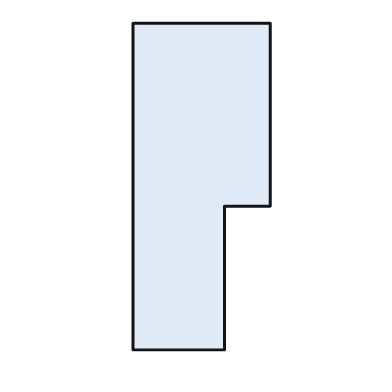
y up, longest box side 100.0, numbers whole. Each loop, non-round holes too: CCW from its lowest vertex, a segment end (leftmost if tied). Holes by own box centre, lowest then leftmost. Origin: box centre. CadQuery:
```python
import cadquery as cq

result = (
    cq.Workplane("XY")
    .moveTo(-21.0, -50.0)
    .lineTo(7.0, -50.0)
    .lineTo(7.0, -6.0)
    .lineTo(21.0, -6.0)
    .lineTo(21.0, 50.0)
    .lineTo(-21.0, 50.0)
    .close()
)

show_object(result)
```